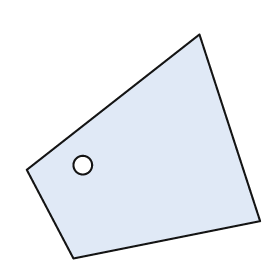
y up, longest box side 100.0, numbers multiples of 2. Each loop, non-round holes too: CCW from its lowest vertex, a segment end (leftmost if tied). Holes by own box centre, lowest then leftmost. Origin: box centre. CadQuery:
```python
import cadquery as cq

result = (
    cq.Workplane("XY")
    .moveTo(-30.0, -48.0)
    .lineTo(50.0, -32.0)
    .lineTo(24.0, 48.0)
    .lineTo(-50.0, -10.0)
    .close()
    .moveTo(-26.0, -8.0)
    .circle(4.0)
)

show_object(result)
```